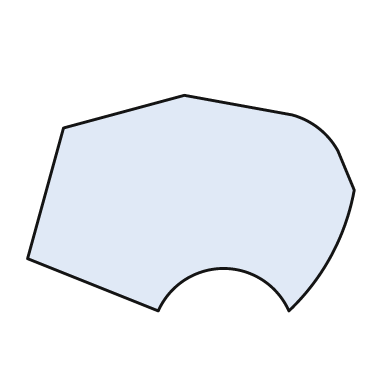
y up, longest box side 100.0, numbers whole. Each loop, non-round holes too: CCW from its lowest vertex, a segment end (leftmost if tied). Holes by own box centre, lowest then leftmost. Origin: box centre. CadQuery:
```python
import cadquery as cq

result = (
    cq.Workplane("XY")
    .moveTo(-10.0, -33.0)
    .threePointArc((10.0, -20.0), (30.0, -33.0))
    .threePointArc((43.0, -16.0), (50.0, 4.0))
    .lineTo(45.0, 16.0)
    .threePointArc((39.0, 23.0), (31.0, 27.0))
    .lineTo(-2.0, 33.0)
    .lineTo(-39.0, 23.0)
    .lineTo(-50.0, -17.0)
    .close()
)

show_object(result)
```